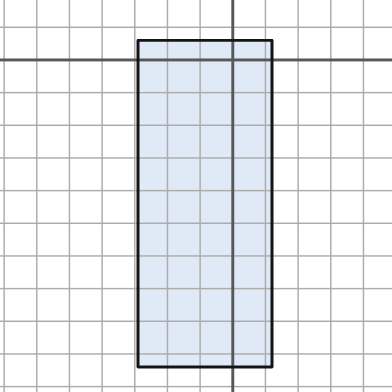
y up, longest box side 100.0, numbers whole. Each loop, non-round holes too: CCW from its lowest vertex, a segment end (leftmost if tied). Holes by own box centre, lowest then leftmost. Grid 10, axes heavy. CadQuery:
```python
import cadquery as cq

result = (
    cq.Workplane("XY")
    .moveTo(-29.0, -94.0)
    .lineTo(12.0, -94.0)
    .lineTo(12.0, 6.0)
    .lineTo(-29.0, 6.0)
    .close()
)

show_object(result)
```